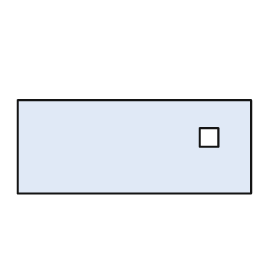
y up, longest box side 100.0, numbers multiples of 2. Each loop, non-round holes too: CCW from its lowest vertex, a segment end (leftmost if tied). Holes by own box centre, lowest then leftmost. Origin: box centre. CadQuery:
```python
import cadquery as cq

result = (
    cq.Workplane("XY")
    .moveTo(-50.0, -20.0)
    .lineTo(50.0, -20.0)
    .lineTo(50.0, 20.0)
    .lineTo(-50.0, 20.0)
    .close()
    .moveTo(28.0, 0.0)
    .lineTo(36.0, 0.0)
    .lineTo(36.0, 8.0)
    .lineTo(28.0, 8.0)
    .close()
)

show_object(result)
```